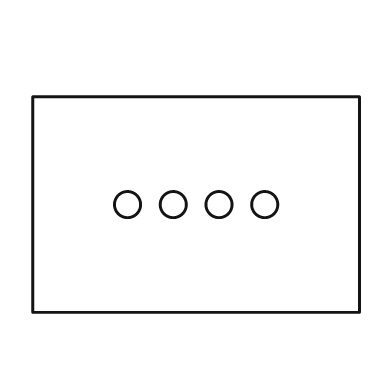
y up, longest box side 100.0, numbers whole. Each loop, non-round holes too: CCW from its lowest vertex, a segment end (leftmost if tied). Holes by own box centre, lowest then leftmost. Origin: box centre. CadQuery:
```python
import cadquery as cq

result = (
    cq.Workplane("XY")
    .moveTo(-50.0, -33.0)
    .lineTo(50.0, -33.0)
    .lineTo(50.0, 33.0)
    .lineTo(-50.0, 33.0)
    .close()
    .moveTo(-21.0, 0.0)
    .circle(4.0)
    .moveTo(-7.0, 0.0)
    .circle(4.0)
    .moveTo(7.0, 0.0)
    .circle(4.0)
    .moveTo(21.0, 0.0)
    .circle(4.0)
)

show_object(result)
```